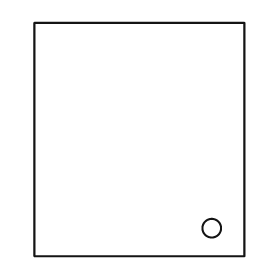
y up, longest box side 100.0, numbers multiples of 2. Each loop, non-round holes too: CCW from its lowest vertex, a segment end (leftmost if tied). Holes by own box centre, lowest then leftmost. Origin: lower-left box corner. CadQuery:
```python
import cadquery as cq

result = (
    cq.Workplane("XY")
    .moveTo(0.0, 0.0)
    .lineTo(90.0, 0.0)
    .lineTo(90.0, 100.0)
    .lineTo(0.0, 100.0)
    .close()
    .moveTo(76.0, 12.0)
    .circle(4.0)
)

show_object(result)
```